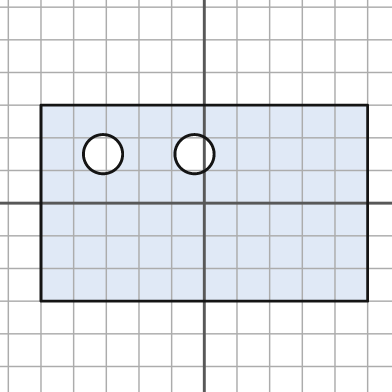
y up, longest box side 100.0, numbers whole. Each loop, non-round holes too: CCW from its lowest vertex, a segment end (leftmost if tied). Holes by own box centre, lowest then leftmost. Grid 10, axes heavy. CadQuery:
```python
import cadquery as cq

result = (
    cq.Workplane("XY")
    .moveTo(-50.0, -30.0)
    .lineTo(50.0, -30.0)
    .lineTo(50.0, 30.0)
    .lineTo(-50.0, 30.0)
    .close()
    .moveTo(-31.0, 15.0)
    .circle(6.0)
    .moveTo(-3.0, 15.0)
    .circle(6.0)
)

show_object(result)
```